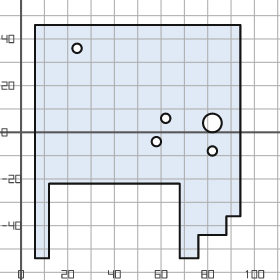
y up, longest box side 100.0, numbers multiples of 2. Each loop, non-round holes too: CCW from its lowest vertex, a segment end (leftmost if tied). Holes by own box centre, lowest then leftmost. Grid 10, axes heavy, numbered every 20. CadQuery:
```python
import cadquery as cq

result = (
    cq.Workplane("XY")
    .moveTo(6.0, -54.0)
    .lineTo(12.0, -54.0)
    .lineTo(12.0, -22.0)
    .lineTo(68.0, -22.0)
    .lineTo(68.0, -54.0)
    .lineTo(76.0, -54.0)
    .lineTo(76.0, -44.0)
    .lineTo(88.0, -44.0)
    .lineTo(88.0, -36.0)
    .lineTo(94.0, -36.0)
    .lineTo(94.0, 46.0)
    .lineTo(6.0, 46.0)
    .close()
    .moveTo(82.0, -8.0)
    .circle(2.0)
    .moveTo(58.0, -4.0)
    .circle(2.0)
    .moveTo(82.0, 4.0)
    .circle(4.0)
    .moveTo(62.0, 6.0)
    .circle(2.0)
    .moveTo(24.0, 36.0)
    .circle(2.0)
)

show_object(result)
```